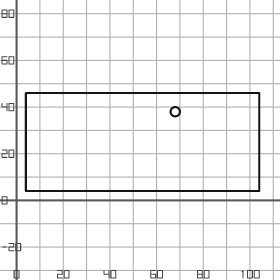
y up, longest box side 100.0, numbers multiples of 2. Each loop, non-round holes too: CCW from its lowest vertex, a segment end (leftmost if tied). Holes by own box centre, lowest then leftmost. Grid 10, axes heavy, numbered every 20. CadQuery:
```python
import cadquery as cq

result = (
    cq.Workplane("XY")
    .moveTo(4.0, 4.0)
    .lineTo(104.0, 4.0)
    .lineTo(104.0, 46.0)
    .lineTo(4.0, 46.0)
    .close()
    .moveTo(68.0, 38.0)
    .circle(2.0)
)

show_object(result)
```